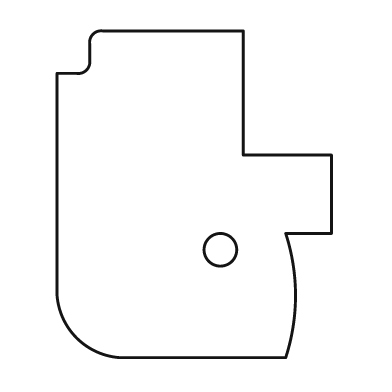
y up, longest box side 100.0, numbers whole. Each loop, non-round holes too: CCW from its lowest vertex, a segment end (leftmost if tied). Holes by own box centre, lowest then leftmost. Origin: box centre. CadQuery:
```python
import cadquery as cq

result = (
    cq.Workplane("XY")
    .moveTo(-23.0, -50.0)
    .lineTo(28.0, -50.0)
    .threePointArc((31.0, -31.0), (28.0, -12.0))
    .lineTo(42.0, -12.0)
    .lineTo(42.0, 12.0)
    .lineTo(15.0, 12.0)
    .lineTo(15.0, 50.0)
    .lineTo(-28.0, 50.0)
    .threePointArc((-31.0, 49.0), (-32.0, 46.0))
    .lineTo(-32.0, 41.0)
    .threePointArc((-33.0, 38.0), (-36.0, 37.0))
    .lineTo(-42.0, 37.0)
    .lineTo(-42.0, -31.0)
    .threePointArc((-36.0, -44.0), (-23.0, -50.0))
    .close()
    .moveTo(8.0, -17.0)
    .circle(5.0)
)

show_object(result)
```